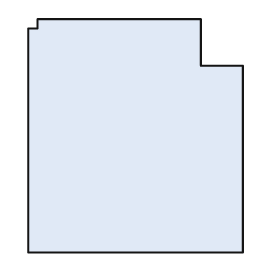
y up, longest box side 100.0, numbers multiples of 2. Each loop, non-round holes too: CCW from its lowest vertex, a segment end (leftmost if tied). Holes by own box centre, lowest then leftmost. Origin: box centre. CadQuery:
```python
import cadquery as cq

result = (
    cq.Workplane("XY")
    .moveTo(-46.0, -50.0)
    .lineTo(46.0, -50.0)
    .lineTo(46.0, 30.0)
    .lineTo(28.0, 30.0)
    .lineTo(28.0, 50.0)
    .lineTo(-42.0, 50.0)
    .lineTo(-42.0, 46.0)
    .lineTo(-46.0, 46.0)
    .close()
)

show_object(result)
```